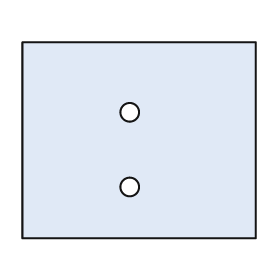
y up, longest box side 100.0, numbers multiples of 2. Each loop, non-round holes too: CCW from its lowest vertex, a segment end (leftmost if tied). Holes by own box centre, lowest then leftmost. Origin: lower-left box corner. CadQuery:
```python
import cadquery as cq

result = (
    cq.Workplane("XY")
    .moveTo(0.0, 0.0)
    .lineTo(100.0, 0.0)
    .lineTo(100.0, 84.0)
    .lineTo(0.0, 84.0)
    .close()
    .moveTo(46.0, 22.0)
    .circle(4.0)
    .moveTo(46.0, 54.0)
    .circle(4.0)
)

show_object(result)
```